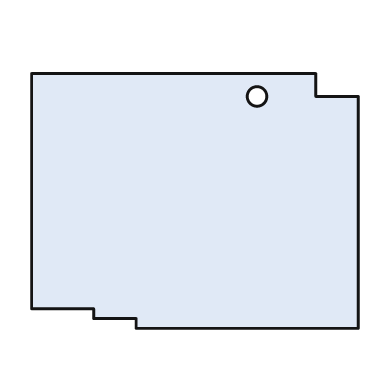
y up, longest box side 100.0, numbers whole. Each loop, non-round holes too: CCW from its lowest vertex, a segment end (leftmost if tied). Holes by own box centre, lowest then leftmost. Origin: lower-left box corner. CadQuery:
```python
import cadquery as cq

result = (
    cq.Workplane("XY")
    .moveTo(32.0, 0.0)
    .lineTo(100.0, 0.0)
    .lineTo(100.0, 71.0)
    .lineTo(87.0, 71.0)
    .lineTo(87.0, 78.0)
    .lineTo(0.0, 78.0)
    .lineTo(0.0, 6.0)
    .lineTo(19.0, 6.0)
    .lineTo(19.0, 3.0)
    .lineTo(32.0, 3.0)
    .close()
    .moveTo(69.0, 71.0)
    .circle(3.0)
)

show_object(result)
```